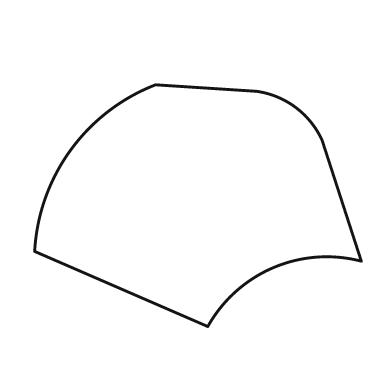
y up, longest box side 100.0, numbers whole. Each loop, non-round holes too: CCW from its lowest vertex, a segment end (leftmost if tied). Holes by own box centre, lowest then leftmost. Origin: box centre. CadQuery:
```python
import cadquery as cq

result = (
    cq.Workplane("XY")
    .moveTo(3.0, -37.0)
    .threePointArc((23.0, -19.0), (50.0, -17.0))
    .lineTo(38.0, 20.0)
    .threePointArc((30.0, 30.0), (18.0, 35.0))
    .lineTo(-13.0, 37.0)
    .threePointArc((-39.0, 17.0), (-50.0, -14.0))
    .close()
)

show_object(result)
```